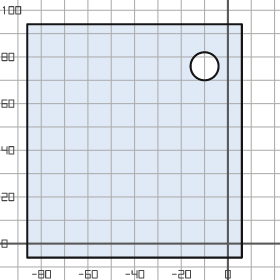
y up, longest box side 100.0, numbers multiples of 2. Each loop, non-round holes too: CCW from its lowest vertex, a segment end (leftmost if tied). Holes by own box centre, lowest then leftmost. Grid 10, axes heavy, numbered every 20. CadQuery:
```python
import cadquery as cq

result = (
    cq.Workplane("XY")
    .moveTo(-86.0, -6.0)
    .lineTo(6.0, -6.0)
    .lineTo(6.0, 94.0)
    .lineTo(-86.0, 94.0)
    .close()
    .moveTo(-10.0, 76.0)
    .circle(6.0)
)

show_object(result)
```